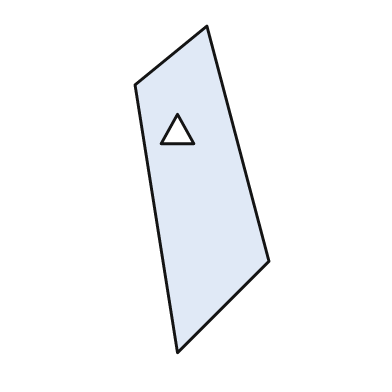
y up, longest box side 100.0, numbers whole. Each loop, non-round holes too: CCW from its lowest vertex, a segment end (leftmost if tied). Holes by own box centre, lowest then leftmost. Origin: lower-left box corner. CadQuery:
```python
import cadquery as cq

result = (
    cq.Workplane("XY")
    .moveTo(13.0, 0.0)
    .lineTo(41.0, 28.0)
    .lineTo(22.0, 100.0)
    .lineTo(0.0, 82.0)
    .close()
    .moveTo(8.0, 64.0)
    .lineTo(18.0, 64.0)
    .lineTo(13.0, 73.0)
    .close()
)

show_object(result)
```